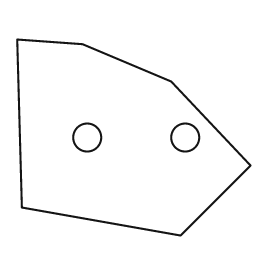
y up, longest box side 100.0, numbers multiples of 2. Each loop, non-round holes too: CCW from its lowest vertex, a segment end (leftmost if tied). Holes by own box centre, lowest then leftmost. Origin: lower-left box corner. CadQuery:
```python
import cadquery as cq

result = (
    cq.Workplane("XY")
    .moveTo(70.0, 0.0)
    .lineTo(100.0, 30.0)
    .lineTo(66.0, 66.0)
    .lineTo(28.0, 82.0)
    .lineTo(0.0, 84.0)
    .lineTo(2.0, 12.0)
    .close()
    .moveTo(30.0, 42.0)
    .circle(6.0)
    .moveTo(72.0, 42.0)
    .circle(6.0)
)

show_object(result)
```